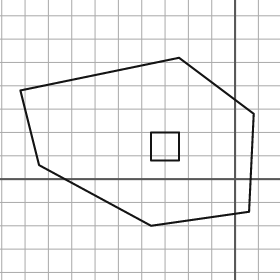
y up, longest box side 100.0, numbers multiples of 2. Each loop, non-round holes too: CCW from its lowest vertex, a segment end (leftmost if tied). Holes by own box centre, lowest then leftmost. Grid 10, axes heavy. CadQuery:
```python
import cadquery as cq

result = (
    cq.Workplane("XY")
    .moveTo(-36.0, -20.0)
    .lineTo(6.0, -14.0)
    .lineTo(8.0, 28.0)
    .lineTo(-24.0, 52.0)
    .lineTo(-92.0, 38.0)
    .lineTo(-84.0, 6.0)
    .close()
    .moveTo(-36.0, 8.0)
    .lineTo(-24.0, 8.0)
    .lineTo(-24.0, 20.0)
    .lineTo(-36.0, 20.0)
    .close()
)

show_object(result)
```